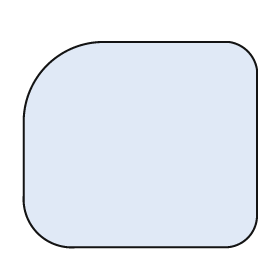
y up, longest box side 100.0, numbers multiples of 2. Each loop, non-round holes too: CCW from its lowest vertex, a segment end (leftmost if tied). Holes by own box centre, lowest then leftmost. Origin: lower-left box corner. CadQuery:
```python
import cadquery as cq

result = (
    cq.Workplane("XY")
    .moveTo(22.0, 0.0)
    .lineTo(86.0, 0.0)
    .threePointArc((96.0, 4.0), (100.0, 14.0))
    .lineTo(100.0, 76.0)
    .threePointArc((96.0, 84.0), (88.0, 88.0))
    .lineTo(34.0, 88.0)
    .threePointArc((10.0, 78.0), (0.0, 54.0))
    .lineTo(0.0, 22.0)
    .threePointArc((6.0, 6.0), (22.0, 0.0))
    .close()
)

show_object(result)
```